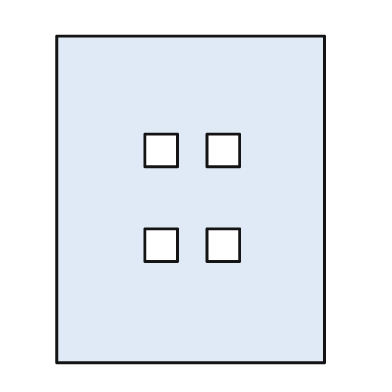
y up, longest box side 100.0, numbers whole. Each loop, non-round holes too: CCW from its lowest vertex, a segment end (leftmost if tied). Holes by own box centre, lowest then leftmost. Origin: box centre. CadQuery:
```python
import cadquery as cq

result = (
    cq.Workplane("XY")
    .moveTo(-41.0, -50.0)
    .lineTo(41.0, -50.0)
    .lineTo(41.0, 50.0)
    .lineTo(-41.0, 50.0)
    .close()
    .moveTo(-14.0, -19.0)
    .lineTo(-4.0, -19.0)
    .lineTo(-4.0, -9.0)
    .lineTo(-14.0, -9.0)
    .close()
    .moveTo(5.0, -19.0)
    .lineTo(15.0, -19.0)
    .lineTo(15.0, -9.0)
    .lineTo(5.0, -9.0)
    .close()
    .moveTo(-14.0, 10.0)
    .lineTo(-4.0, 10.0)
    .lineTo(-4.0, 20.0)
    .lineTo(-14.0, 20.0)
    .close()
    .moveTo(5.0, 10.0)
    .lineTo(15.0, 10.0)
    .lineTo(15.0, 20.0)
    .lineTo(5.0, 20.0)
    .close()
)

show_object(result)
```